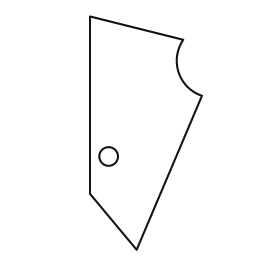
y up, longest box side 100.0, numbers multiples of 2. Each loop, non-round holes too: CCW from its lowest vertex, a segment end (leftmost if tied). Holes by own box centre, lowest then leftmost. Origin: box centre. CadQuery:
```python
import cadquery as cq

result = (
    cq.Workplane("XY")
    .moveTo(-4.0, -50.0)
    .lineTo(24.0, 16.0)
    .threePointArc((14.0, 26.0), (16.0, 40.0))
    .lineTo(-24.0, 50.0)
    .lineTo(-24.0, -26.0)
    .close()
    .moveTo(-16.0, -10.0)
    .circle(4.0)
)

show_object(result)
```